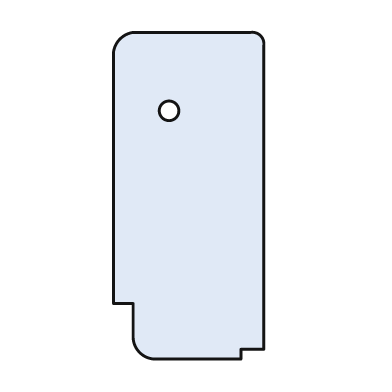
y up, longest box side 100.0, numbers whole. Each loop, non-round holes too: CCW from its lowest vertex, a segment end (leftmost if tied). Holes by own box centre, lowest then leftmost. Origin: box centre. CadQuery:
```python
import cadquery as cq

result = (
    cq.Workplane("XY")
    .moveTo(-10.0, -50.0)
    .lineTo(16.0, -50.0)
    .lineTo(16.0, -47.0)
    .lineTo(23.0, -47.0)
    .lineTo(23.0, 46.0)
    .threePointArc((22.0, 49.0), (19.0, 50.0))
    .lineTo(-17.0, 50.0)
    .threePointArc((-21.0, 48.0), (-23.0, 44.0))
    .lineTo(-23.0, -33.0)
    .lineTo(-17.0, -33.0)
    .lineTo(-17.0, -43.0)
    .threePointArc((-15.0, -48.0), (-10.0, -50.0))
    .close()
    .moveTo(-6.0, 26.0)
    .circle(3.0)
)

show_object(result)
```